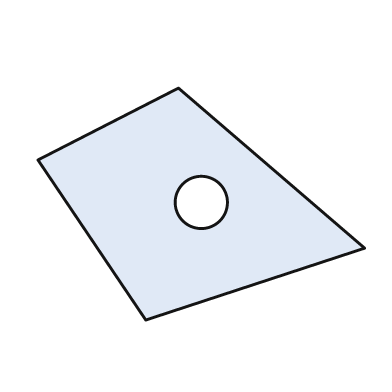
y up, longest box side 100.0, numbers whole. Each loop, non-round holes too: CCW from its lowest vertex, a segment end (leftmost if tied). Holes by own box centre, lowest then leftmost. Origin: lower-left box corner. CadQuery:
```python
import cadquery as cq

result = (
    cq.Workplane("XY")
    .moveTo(33.0, 0.0)
    .lineTo(100.0, 22.0)
    .lineTo(43.0, 71.0)
    .lineTo(0.0, 49.0)
    .close()
    .moveTo(50.0, 36.0)
    .circle(8.0)
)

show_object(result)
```